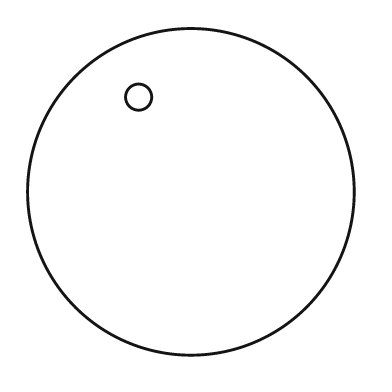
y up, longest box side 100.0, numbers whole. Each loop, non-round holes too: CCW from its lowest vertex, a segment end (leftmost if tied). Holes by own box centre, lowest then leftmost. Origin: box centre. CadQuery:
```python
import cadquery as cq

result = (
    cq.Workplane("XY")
    .moveTo(0.0, 0.0)
    .circle(50.0)
    .moveTo(-16.0, 29.0)
    .circle(4.0)
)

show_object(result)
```